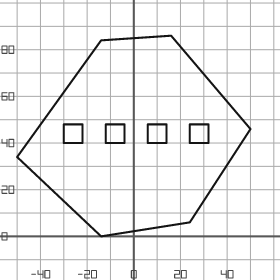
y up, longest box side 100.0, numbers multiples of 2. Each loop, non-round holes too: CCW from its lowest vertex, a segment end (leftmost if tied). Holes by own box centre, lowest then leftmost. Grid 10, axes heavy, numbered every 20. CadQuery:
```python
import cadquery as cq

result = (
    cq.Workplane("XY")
    .moveTo(-14.0, 0.0)
    .lineTo(24.0, 6.0)
    .lineTo(50.0, 46.0)
    .lineTo(16.0, 86.0)
    .lineTo(-14.0, 84.0)
    .lineTo(-50.0, 34.0)
    .close()
    .moveTo(-30.0, 40.0)
    .lineTo(-22.0, 40.0)
    .lineTo(-22.0, 48.0)
    .lineTo(-30.0, 48.0)
    .close()
    .moveTo(-12.0, 40.0)
    .lineTo(-4.0, 40.0)
    .lineTo(-4.0, 48.0)
    .lineTo(-12.0, 48.0)
    .close()
    .moveTo(6.0, 40.0)
    .lineTo(14.0, 40.0)
    .lineTo(14.0, 48.0)
    .lineTo(6.0, 48.0)
    .close()
    .moveTo(24.0, 40.0)
    .lineTo(32.0, 40.0)
    .lineTo(32.0, 48.0)
    .lineTo(24.0, 48.0)
    .close()
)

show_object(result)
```